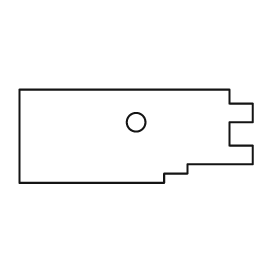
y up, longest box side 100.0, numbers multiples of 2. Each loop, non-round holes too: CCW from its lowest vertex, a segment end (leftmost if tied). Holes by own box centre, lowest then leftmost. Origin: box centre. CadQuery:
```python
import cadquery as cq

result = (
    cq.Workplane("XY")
    .moveTo(-50.0, -20.0)
    .lineTo(12.0, -20.0)
    .lineTo(12.0, -16.0)
    .lineTo(22.0, -16.0)
    .lineTo(22.0, -12.0)
    .lineTo(50.0, -12.0)
    .lineTo(50.0, -4.0)
    .lineTo(40.0, -4.0)
    .lineTo(40.0, 6.0)
    .lineTo(50.0, 6.0)
    .lineTo(50.0, 14.0)
    .lineTo(40.0, 14.0)
    .lineTo(40.0, 20.0)
    .lineTo(-50.0, 20.0)
    .close()
    .moveTo(0.0, 6.0)
    .circle(4.0)
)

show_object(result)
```